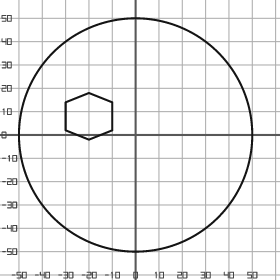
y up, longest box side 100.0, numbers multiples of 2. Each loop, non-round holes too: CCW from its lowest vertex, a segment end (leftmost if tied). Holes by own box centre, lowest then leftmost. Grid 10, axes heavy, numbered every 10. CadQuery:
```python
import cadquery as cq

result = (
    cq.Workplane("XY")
    .moveTo(0.0, 0.0)
    .circle(50.0)
    .moveTo(-20.0, -2.0)
    .lineTo(-10.0, 2.0)
    .lineTo(-10.0, 14.0)
    .lineTo(-20.0, 18.0)
    .lineTo(-30.0, 14.0)
    .lineTo(-30.0, 2.0)
    .close()
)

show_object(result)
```